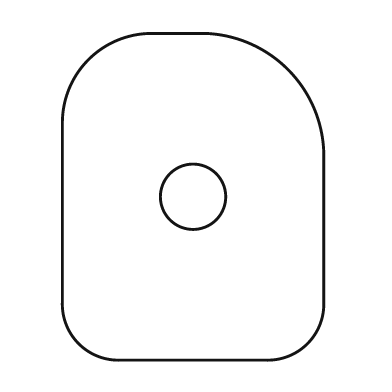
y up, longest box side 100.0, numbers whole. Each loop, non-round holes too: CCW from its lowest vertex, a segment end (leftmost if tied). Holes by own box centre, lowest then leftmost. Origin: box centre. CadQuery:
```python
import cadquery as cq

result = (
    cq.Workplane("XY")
    .moveTo(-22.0, -50.0)
    .lineTo(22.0, -50.0)
    .threePointArc((35.0, -45.0), (40.0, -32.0))
    .lineTo(40.0, 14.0)
    .threePointArc((29.0, 39.0), (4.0, 50.0))
    .lineTo(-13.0, 50.0)
    .threePointArc((-32.0, 42.0), (-40.0, 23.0))
    .lineTo(-40.0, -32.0)
    .threePointArc((-35.0, -45.0), (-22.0, -50.0))
    .close()
    .moveTo(0.0, 0.0)
    .circle(10.0)
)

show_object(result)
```